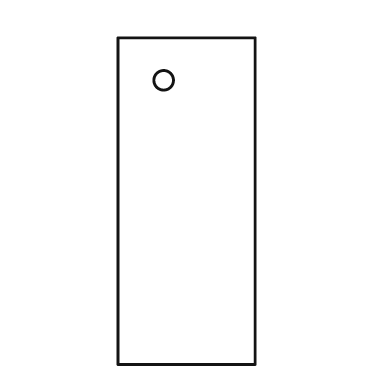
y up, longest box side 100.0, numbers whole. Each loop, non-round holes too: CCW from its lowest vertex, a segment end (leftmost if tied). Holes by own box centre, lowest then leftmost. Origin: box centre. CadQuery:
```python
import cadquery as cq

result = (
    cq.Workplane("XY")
    .moveTo(-21.0, -50.0)
    .lineTo(21.0, -50.0)
    .lineTo(21.0, 50.0)
    .lineTo(-21.0, 50.0)
    .close()
    .moveTo(-7.0, 37.0)
    .circle(3.0)
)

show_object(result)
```